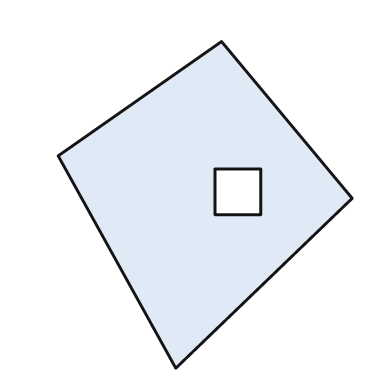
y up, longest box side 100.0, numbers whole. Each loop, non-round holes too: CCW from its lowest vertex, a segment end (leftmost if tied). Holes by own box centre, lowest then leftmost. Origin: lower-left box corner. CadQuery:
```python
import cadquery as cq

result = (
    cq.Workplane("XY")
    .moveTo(36.0, 0.0)
    .lineTo(90.0, 52.0)
    .lineTo(50.0, 100.0)
    .lineTo(0.0, 65.0)
    .close()
    .moveTo(48.0, 47.0)
    .lineTo(62.0, 47.0)
    .lineTo(62.0, 61.0)
    .lineTo(48.0, 61.0)
    .close()
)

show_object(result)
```